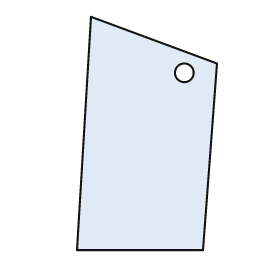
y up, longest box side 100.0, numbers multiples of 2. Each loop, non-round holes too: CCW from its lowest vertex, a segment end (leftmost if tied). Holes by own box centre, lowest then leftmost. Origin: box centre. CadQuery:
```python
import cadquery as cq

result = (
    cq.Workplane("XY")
    .moveTo(-30.0, -50.0)
    .lineTo(24.0, -50.0)
    .lineTo(30.0, 30.0)
    .lineTo(-24.0, 50.0)
    .close()
    .moveTo(16.0, 26.0)
    .circle(4.0)
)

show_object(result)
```